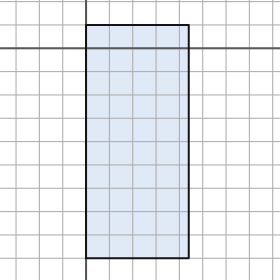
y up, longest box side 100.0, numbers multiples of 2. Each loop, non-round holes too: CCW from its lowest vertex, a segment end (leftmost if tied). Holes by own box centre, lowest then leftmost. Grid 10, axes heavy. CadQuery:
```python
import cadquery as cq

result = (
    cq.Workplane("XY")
    .moveTo(0.0, -90.0)
    .lineTo(44.0, -90.0)
    .lineTo(44.0, 10.0)
    .lineTo(0.0, 10.0)
    .close()
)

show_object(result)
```